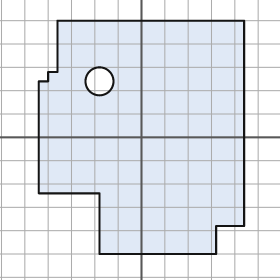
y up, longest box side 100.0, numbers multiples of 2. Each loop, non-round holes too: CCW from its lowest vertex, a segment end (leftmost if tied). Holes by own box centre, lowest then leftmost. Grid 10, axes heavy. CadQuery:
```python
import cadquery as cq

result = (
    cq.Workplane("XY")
    .moveTo(-18.0, -50.0)
    .lineTo(32.0, -50.0)
    .lineTo(32.0, -38.0)
    .lineTo(44.0, -38.0)
    .lineTo(44.0, 50.0)
    .lineTo(-36.0, 50.0)
    .lineTo(-36.0, 28.0)
    .lineTo(-40.0, 28.0)
    .lineTo(-40.0, 24.0)
    .lineTo(-44.0, 24.0)
    .lineTo(-44.0, -24.0)
    .lineTo(-18.0, -24.0)
    .close()
    .moveTo(-18.0, 24.0)
    .circle(6.0)
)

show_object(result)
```